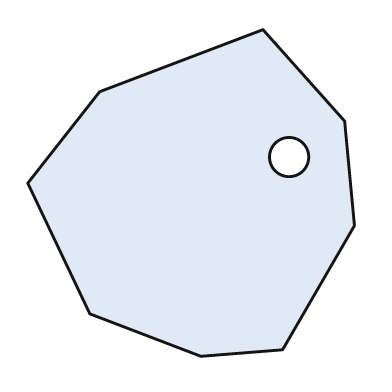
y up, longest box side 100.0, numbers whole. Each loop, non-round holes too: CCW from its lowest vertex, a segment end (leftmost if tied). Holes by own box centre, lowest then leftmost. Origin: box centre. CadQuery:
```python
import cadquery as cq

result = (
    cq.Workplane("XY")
    .moveTo(3.0, -50.0)
    .lineTo(28.0, -48.0)
    .lineTo(50.0, -10.0)
    .lineTo(47.0, 22.0)
    .lineTo(22.0, 50.0)
    .lineTo(-28.0, 31.0)
    .lineTo(-50.0, 3.0)
    .lineTo(-31.0, -37.0)
    .close()
    .moveTo(30.0, 11.0)
    .circle(6.0)
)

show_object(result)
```